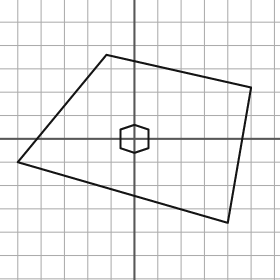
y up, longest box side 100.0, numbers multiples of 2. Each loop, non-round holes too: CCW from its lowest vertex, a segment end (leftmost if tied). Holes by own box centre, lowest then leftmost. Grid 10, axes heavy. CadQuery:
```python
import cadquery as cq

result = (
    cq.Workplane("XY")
    .moveTo(40.0, -36.0)
    .lineTo(50.0, 22.0)
    .lineTo(-12.0, 36.0)
    .lineTo(-50.0, -10.0)
    .close()
    .moveTo(0.0, -6.0)
    .lineTo(6.0, -4.0)
    .lineTo(6.0, 4.0)
    .lineTo(0.0, 6.0)
    .lineTo(-6.0, 4.0)
    .lineTo(-6.0, -4.0)
    .close()
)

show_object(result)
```